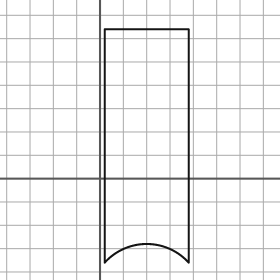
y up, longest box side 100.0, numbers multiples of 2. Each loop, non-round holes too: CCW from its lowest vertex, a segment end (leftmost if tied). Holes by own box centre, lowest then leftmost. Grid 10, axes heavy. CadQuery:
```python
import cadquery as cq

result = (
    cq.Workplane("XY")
    .moveTo(2.0, -36.0)
    .threePointArc((20.0, -28.0), (38.0, -36.0))
    .lineTo(38.0, 64.0)
    .lineTo(2.0, 64.0)
    .close()
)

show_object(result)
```